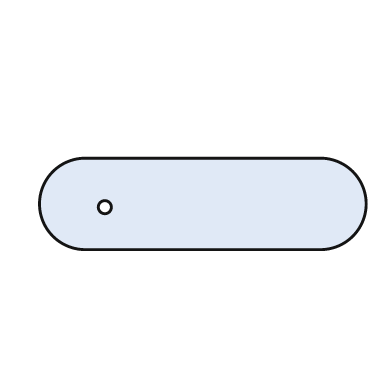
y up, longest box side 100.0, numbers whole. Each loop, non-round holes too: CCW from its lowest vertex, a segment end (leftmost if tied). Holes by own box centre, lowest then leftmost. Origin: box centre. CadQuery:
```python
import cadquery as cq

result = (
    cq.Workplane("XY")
    .moveTo(-36.0, -14.0)
    .lineTo(36.0, -14.0)
    .threePointArc((50.0, 0.0), (36.0, 14.0))
    .lineTo(-36.0, 14.0)
    .threePointArc((-50.0, 0.0), (-36.0, -14.0))
    .close()
    .moveTo(-30.0, -1.0)
    .circle(2.0)
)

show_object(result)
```